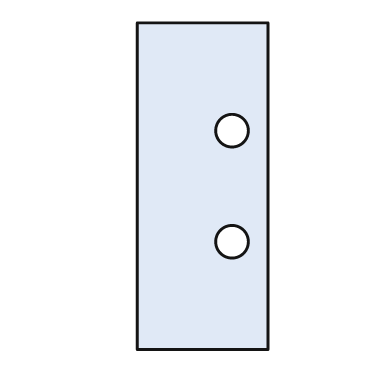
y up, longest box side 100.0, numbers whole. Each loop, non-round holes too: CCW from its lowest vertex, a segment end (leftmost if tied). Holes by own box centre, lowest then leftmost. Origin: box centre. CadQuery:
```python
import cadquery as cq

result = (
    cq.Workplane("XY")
    .moveTo(-20.0, -50.0)
    .lineTo(20.0, -50.0)
    .lineTo(20.0, 50.0)
    .lineTo(-20.0, 50.0)
    .close()
    .moveTo(9.0, -17.0)
    .circle(5.0)
    .moveTo(9.0, 17.0)
    .circle(5.0)
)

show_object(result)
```